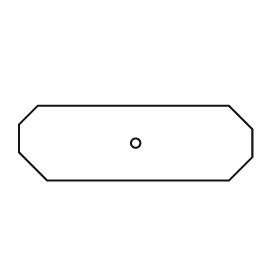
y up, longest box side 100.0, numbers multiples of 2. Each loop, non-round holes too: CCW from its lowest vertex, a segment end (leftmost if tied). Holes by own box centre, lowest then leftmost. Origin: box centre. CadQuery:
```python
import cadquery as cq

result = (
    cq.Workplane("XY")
    .moveTo(-38.0, -16.0)
    .lineTo(40.0, -16.0)
    .lineTo(50.0, -6.0)
    .lineTo(50.0, 6.0)
    .lineTo(40.0, 16.0)
    .lineTo(-42.0, 16.0)
    .lineTo(-50.0, 8.0)
    .lineTo(-50.0, -4.0)
    .close()
    .moveTo(0.0, 0.0)
    .circle(2.0)
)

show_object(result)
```